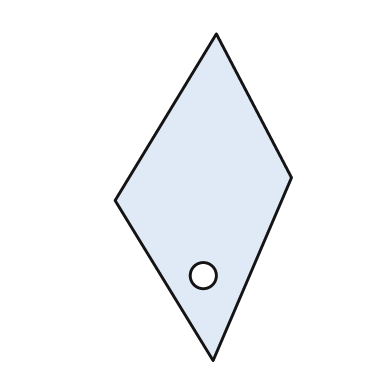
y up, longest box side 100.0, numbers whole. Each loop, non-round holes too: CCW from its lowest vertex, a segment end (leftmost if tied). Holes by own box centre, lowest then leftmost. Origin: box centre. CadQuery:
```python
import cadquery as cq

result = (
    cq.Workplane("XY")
    .moveTo(3.0, -50.0)
    .lineTo(27.0, 6.0)
    .lineTo(4.0, 50.0)
    .lineTo(-27.0, -1.0)
    .close()
    .moveTo(0.0, -24.0)
    .circle(4.0)
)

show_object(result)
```